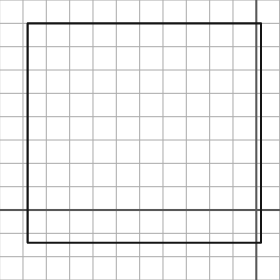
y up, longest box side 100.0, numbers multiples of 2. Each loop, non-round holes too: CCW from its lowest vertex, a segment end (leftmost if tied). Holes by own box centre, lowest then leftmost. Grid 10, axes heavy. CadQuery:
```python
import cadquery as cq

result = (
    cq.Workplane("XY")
    .moveTo(-98.0, -14.0)
    .lineTo(2.0, -14.0)
    .lineTo(2.0, 80.0)
    .lineTo(-98.0, 80.0)
    .close()
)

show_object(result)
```